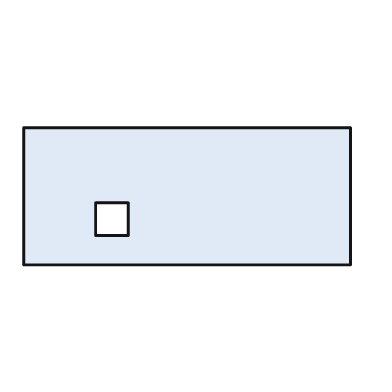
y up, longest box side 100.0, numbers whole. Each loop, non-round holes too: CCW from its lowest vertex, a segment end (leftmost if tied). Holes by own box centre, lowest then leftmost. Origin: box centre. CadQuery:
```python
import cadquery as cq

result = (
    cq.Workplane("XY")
    .moveTo(-50.0, -21.0)
    .lineTo(50.0, -21.0)
    .lineTo(50.0, 21.0)
    .lineTo(-50.0, 21.0)
    .close()
    .moveTo(-28.0, -12.0)
    .lineTo(-18.0, -12.0)
    .lineTo(-18.0, -2.0)
    .lineTo(-28.0, -2.0)
    .close()
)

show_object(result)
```